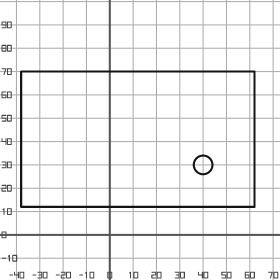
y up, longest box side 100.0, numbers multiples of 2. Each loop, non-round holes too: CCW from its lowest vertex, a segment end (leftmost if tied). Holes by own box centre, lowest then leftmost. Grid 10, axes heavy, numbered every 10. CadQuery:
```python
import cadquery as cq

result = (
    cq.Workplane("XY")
    .moveTo(-38.0, 12.0)
    .lineTo(62.0, 12.0)
    .lineTo(62.0, 70.0)
    .lineTo(-38.0, 70.0)
    .close()
    .moveTo(40.0, 30.0)
    .circle(4.0)
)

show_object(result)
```